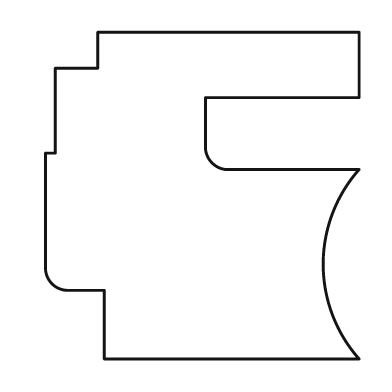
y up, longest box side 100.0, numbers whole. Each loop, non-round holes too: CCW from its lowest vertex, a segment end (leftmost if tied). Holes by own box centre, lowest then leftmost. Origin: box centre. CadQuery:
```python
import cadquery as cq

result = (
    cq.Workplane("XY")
    .moveTo(-30.0, -50.0)
    .lineTo(48.0, -50.0)
    .threePointArc((37.0, -21.0), (48.0, 8.0))
    .lineTo(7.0, 8.0)
    .threePointArc((3.0, 10.0), (1.0, 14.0))
    .lineTo(1.0, 30.0)
    .lineTo(48.0, 30.0)
    .lineTo(48.0, 50.0)
    .lineTo(-32.0, 50.0)
    .lineTo(-32.0, 39.0)
    .lineTo(-45.0, 39.0)
    .lineTo(-45.0, 13.0)
    .lineTo(-48.0, 13.0)
    .lineTo(-48.0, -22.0)
    .threePointArc((-46.0, -27.0), (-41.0, -29.0))
    .lineTo(-30.0, -29.0)
    .close()
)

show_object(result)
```